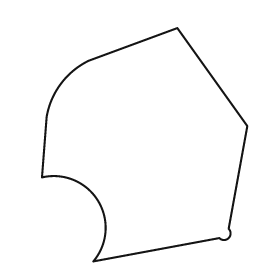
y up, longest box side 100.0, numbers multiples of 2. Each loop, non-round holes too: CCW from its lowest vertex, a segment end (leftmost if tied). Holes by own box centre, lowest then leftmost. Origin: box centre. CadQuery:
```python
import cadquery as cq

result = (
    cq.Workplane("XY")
    .moveTo(-22.0, -50.0)
    .lineTo(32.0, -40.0)
    .threePointArc((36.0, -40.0), (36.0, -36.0))
    .lineTo(44.0, 8.0)
    .lineTo(14.0, 50.0)
    .lineTo(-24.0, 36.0)
    .threePointArc((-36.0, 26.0), (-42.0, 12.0))
    .lineTo(-44.0, -14.0)
    .threePointArc((-20.0, -24.0), (-22.0, -50.0))
    .close()
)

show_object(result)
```